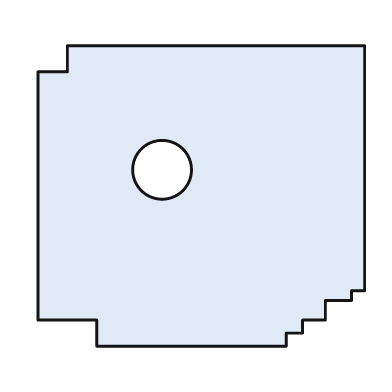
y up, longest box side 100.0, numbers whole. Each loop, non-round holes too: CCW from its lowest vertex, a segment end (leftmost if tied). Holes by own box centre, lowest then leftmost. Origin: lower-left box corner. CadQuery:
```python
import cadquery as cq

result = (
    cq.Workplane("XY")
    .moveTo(18.0, 0.0)
    .lineTo(76.0, 0.0)
    .lineTo(76.0, 4.0)
    .lineTo(81.0, 4.0)
    .lineTo(81.0, 8.0)
    .lineTo(88.0, 8.0)
    .lineTo(88.0, 14.0)
    .lineTo(96.0, 14.0)
    .lineTo(96.0, 17.0)
    .lineTo(100.0, 17.0)
    .lineTo(100.0, 92.0)
    .lineTo(9.0, 92.0)
    .lineTo(9.0, 84.0)
    .lineTo(0.0, 84.0)
    .lineTo(0.0, 8.0)
    .lineTo(18.0, 8.0)
    .close()
    .moveTo(38.0, 54.0)
    .circle(9.0)
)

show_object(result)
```